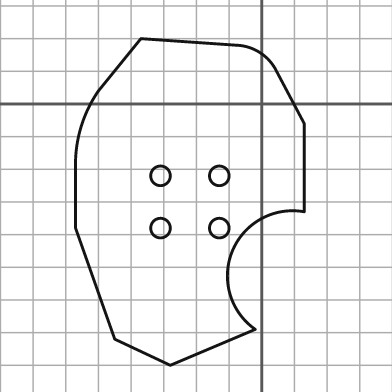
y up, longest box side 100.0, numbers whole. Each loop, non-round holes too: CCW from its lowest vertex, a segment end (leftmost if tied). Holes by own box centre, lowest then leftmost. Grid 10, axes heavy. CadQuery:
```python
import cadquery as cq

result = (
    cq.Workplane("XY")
    .moveTo(-28.0, -80.0)
    .lineTo(-2.0, -69.0)
    .threePointArc((-9.0, -45.0), (13.0, -33.0))
    .lineTo(13.0, -6.0)
    .lineTo(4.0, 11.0)
    .threePointArc((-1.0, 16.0), (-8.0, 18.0))
    .lineTo(-37.0, 20.0)
    .lineTo(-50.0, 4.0)
    .threePointArc((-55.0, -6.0), (-57.0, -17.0))
    .lineTo(-57.0, -38.0)
    .lineTo(-45.0, -72.0)
    .close()
    .moveTo(-31.0, -38.0)
    .circle(3.0)
    .moveTo(-13.0, -38.0)
    .circle(3.0)
    .moveTo(-31.0, -22.0)
    .circle(3.0)
    .moveTo(-13.0, -22.0)
    .circle(3.0)
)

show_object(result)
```